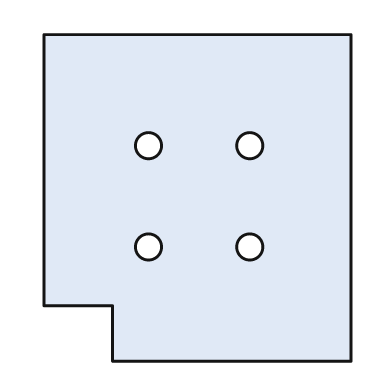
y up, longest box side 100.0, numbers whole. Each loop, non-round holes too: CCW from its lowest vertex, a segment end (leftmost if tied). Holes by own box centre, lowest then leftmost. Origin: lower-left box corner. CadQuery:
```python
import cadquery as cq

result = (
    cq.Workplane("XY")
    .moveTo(21.0, 0.0)
    .lineTo(94.0, 0.0)
    .lineTo(94.0, 100.0)
    .lineTo(0.0, 100.0)
    .lineTo(0.0, 17.0)
    .lineTo(21.0, 17.0)
    .close()
    .moveTo(32.0, 35.0)
    .circle(4.0)
    .moveTo(63.0, 35.0)
    .circle(4.0)
    .moveTo(32.0, 66.0)
    .circle(4.0)
    .moveTo(63.0, 66.0)
    .circle(4.0)
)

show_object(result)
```